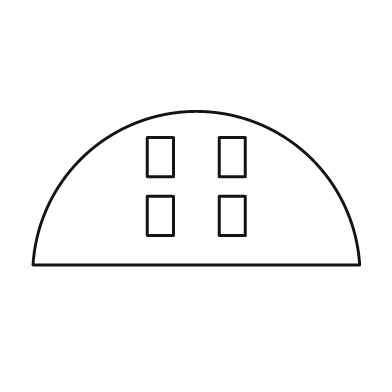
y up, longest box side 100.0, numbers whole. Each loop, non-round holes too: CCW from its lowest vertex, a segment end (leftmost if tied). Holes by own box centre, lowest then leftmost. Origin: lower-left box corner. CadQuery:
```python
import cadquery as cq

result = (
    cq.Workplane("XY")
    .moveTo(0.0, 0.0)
    .lineTo(100.0, 0.0)
    .threePointArc((50.0, 47.0), (0.0, 0.0))
    .close()
    .moveTo(35.0, 9.0)
    .lineTo(43.0, 9.0)
    .lineTo(43.0, 21.0)
    .lineTo(35.0, 21.0)
    .close()
    .moveTo(57.0, 9.0)
    .lineTo(65.0, 9.0)
    .lineTo(65.0, 21.0)
    .lineTo(57.0, 21.0)
    .close()
    .moveTo(35.0, 27.0)
    .lineTo(43.0, 27.0)
    .lineTo(43.0, 39.0)
    .lineTo(35.0, 39.0)
    .close()
    .moveTo(57.0, 27.0)
    .lineTo(65.0, 27.0)
    .lineTo(65.0, 39.0)
    .lineTo(57.0, 39.0)
    .close()
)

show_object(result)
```